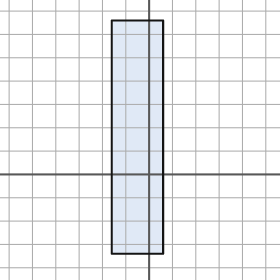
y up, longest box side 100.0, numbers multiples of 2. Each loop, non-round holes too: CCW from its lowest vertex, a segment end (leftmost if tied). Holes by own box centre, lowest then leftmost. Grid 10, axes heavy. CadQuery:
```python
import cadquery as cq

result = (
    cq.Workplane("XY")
    .moveTo(-16.0, -34.0)
    .lineTo(6.0, -34.0)
    .lineTo(6.0, 66.0)
    .lineTo(-16.0, 66.0)
    .close()
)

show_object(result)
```